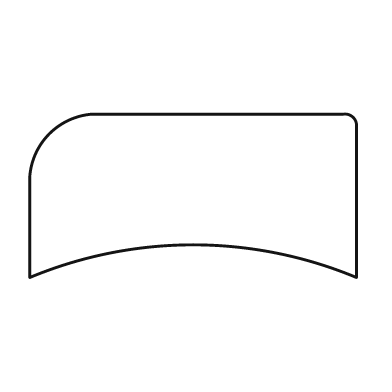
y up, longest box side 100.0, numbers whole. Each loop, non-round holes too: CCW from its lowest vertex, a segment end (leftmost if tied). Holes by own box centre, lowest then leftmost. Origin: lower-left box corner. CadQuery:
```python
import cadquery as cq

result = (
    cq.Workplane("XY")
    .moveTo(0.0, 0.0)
    .threePointArc((50.0, 10.0), (100.0, 0.0))
    .lineTo(100.0, 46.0)
    .threePointArc((99.0, 49.0), (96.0, 50.0))
    .lineTo(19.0, 50.0)
    .threePointArc((6.0, 44.0), (0.0, 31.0))
    .close()
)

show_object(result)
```